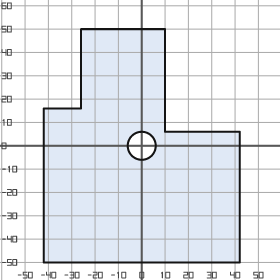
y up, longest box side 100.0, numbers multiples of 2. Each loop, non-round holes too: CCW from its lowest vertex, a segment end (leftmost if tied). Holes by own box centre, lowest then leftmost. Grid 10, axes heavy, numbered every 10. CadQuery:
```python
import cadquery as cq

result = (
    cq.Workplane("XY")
    .moveTo(-42.0, -50.0)
    .lineTo(42.0, -50.0)
    .lineTo(42.0, 6.0)
    .lineTo(10.0, 6.0)
    .lineTo(10.0, 50.0)
    .lineTo(-26.0, 50.0)
    .lineTo(-26.0, 16.0)
    .lineTo(-42.0, 16.0)
    .close()
    .moveTo(0.0, 0.0)
    .circle(6.0)
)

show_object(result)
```